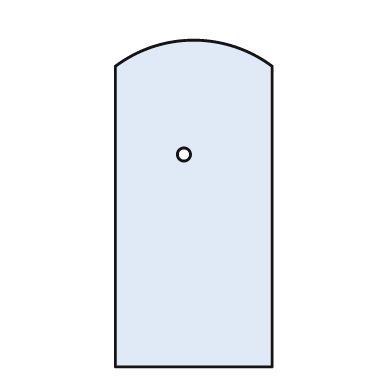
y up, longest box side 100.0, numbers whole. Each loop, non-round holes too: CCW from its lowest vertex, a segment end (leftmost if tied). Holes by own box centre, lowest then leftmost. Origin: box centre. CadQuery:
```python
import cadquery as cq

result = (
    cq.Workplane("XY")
    .moveTo(-24.0, -50.0)
    .lineTo(24.0, -50.0)
    .lineTo(24.0, 42.0)
    .threePointArc((0.0, 50.0), (-24.0, 42.0))
    .close()
    .moveTo(-3.0, 15.0)
    .circle(2.0)
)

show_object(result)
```